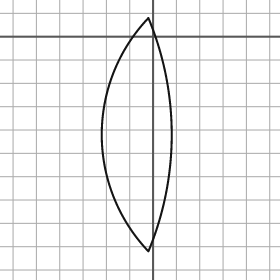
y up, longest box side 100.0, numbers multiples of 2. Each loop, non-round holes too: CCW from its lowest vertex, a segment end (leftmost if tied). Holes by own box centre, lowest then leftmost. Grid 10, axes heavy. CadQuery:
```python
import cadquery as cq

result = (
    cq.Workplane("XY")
    .moveTo(-2.0, -92.0)
    .threePointArc((8.0, -42.0), (-2.0, 8.0))
    .threePointArc((-22.0, -42.0), (-2.0, -92.0))
    .close()
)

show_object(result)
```